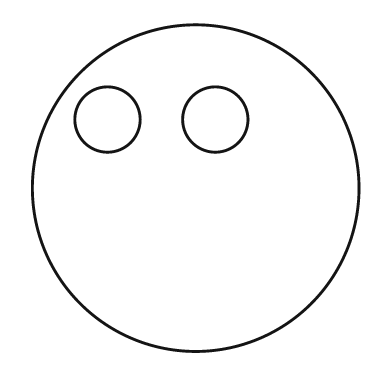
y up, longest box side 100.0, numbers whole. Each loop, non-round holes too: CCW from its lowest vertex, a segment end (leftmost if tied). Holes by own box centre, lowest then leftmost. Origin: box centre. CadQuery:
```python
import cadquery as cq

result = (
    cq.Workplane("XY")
    .moveTo(0.0, 0.0)
    .circle(50.0)
    .moveTo(-27.0, 21.0)
    .circle(10.0)
    .moveTo(6.0, 21.0)
    .circle(10.0)
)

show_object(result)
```